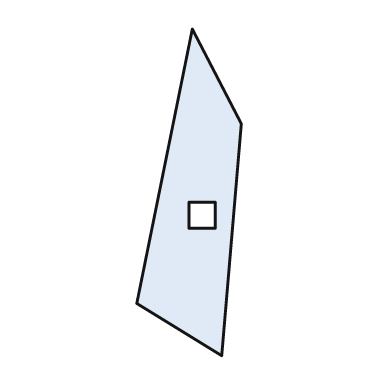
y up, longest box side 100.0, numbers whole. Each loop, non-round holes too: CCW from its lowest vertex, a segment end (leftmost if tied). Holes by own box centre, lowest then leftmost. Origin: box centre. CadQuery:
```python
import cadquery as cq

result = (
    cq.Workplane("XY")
    .moveTo(10.0, -50.0)
    .lineTo(16.0, 21.0)
    .lineTo(1.0, 50.0)
    .lineTo(-16.0, -34.0)
    .close()
    .moveTo(0.0, -11.0)
    .lineTo(8.0, -11.0)
    .lineTo(8.0, -3.0)
    .lineTo(0.0, -3.0)
    .close()
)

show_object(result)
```